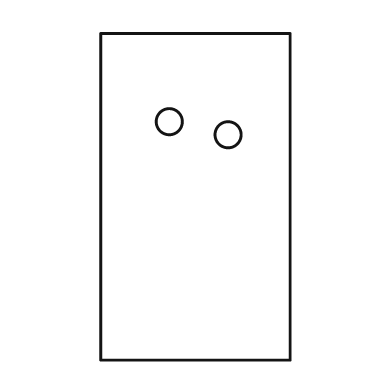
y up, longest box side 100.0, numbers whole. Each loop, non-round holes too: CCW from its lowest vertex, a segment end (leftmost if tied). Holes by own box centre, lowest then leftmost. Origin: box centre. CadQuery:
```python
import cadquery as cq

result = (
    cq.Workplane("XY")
    .moveTo(-29.0, -50.0)
    .lineTo(29.0, -50.0)
    .lineTo(29.0, 50.0)
    .lineTo(-29.0, 50.0)
    .close()
    .moveTo(10.0, 19.0)
    .circle(4.0)
    .moveTo(-8.0, 23.0)
    .circle(4.0)
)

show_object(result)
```